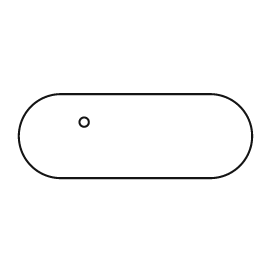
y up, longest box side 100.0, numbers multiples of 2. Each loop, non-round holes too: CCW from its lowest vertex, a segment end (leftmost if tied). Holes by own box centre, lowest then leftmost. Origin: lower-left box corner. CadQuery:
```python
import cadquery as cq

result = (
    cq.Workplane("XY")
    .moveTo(18.0, 0.0)
    .lineTo(82.0, 0.0)
    .threePointArc((100.0, 18.0), (82.0, 36.0))
    .lineTo(18.0, 36.0)
    .threePointArc((0.0, 18.0), (18.0, 0.0))
    .close()
    .moveTo(28.0, 24.0)
    .circle(2.0)
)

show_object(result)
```